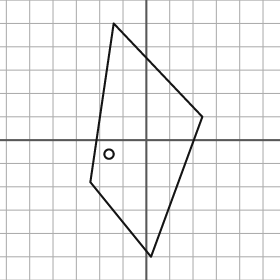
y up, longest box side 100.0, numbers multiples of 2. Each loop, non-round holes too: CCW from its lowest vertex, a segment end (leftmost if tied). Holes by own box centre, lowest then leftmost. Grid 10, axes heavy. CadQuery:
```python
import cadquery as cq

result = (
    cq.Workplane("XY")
    .moveTo(2.0, -50.0)
    .lineTo(24.0, 10.0)
    .lineTo(-14.0, 50.0)
    .lineTo(-24.0, -18.0)
    .close()
    .moveTo(-16.0, -6.0)
    .circle(2.0)
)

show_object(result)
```